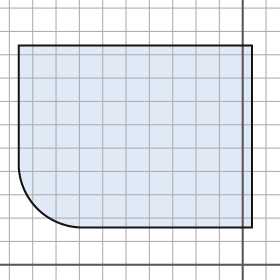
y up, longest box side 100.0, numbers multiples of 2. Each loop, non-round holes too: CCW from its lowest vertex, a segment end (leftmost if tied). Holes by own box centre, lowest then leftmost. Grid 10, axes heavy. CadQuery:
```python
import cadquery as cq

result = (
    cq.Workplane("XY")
    .moveTo(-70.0, 16.0)
    .lineTo(4.0, 16.0)
    .lineTo(4.0, 94.0)
    .lineTo(-96.0, 94.0)
    .lineTo(-96.0, 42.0)
    .threePointArc((-88.0, 24.0), (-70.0, 16.0))
    .close()
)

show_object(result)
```